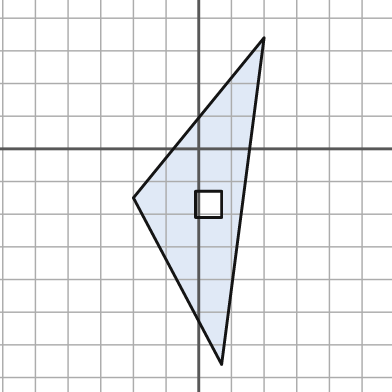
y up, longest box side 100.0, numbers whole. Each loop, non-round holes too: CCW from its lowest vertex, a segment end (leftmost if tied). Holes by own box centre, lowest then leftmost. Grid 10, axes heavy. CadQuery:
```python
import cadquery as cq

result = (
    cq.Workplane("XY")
    .moveTo(7.0, -66.0)
    .lineTo(20.0, 34.0)
    .lineTo(-20.0, -15.0)
    .close()
    .moveTo(-1.0, -21.0)
    .lineTo(7.0, -21.0)
    .lineTo(7.0, -13.0)
    .lineTo(-1.0, -13.0)
    .close()
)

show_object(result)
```